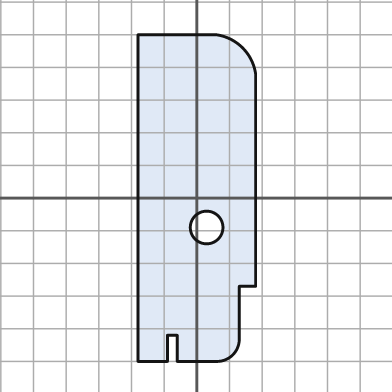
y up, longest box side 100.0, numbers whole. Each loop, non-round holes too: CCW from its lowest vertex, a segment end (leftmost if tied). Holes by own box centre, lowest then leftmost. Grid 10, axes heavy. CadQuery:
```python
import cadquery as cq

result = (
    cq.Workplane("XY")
    .moveTo(-18.0, -50.0)
    .lineTo(-9.0, -50.0)
    .lineTo(-9.0, -42.0)
    .lineTo(-6.0, -42.0)
    .lineTo(-6.0, -50.0)
    .lineTo(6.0, -50.0)
    .threePointArc((11.0, -48.0), (13.0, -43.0))
    .lineTo(13.0, -27.0)
    .lineTo(18.0, -27.0)
    .lineTo(18.0, 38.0)
    .threePointArc((14.0, 46.0), (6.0, 50.0))
    .lineTo(-18.0, 50.0)
    .close()
    .moveTo(3.0, -9.0)
    .circle(5.0)
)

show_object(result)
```